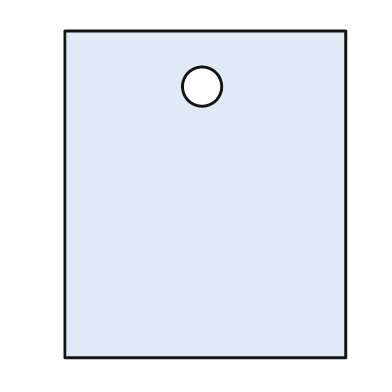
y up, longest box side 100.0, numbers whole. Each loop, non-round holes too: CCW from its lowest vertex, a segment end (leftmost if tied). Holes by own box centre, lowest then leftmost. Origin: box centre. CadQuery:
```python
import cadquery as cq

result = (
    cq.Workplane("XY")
    .moveTo(-43.0, -50.0)
    .lineTo(43.0, -50.0)
    .lineTo(43.0, 50.0)
    .lineTo(-43.0, 50.0)
    .close()
    .moveTo(-1.0, 33.0)
    .circle(6.0)
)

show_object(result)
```